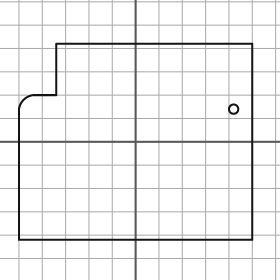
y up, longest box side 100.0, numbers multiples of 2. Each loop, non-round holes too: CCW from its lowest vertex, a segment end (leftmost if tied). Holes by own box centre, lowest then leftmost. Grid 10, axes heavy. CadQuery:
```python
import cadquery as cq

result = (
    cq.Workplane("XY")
    .moveTo(-50.0, -42.0)
    .lineTo(50.0, -42.0)
    .lineTo(50.0, 42.0)
    .lineTo(-34.0, 42.0)
    .lineTo(-34.0, 20.0)
    .lineTo(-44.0, 20.0)
    .threePointArc((-48.0, 18.0), (-50.0, 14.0))
    .close()
    .moveTo(42.0, 14.0)
    .circle(2.0)
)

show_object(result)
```